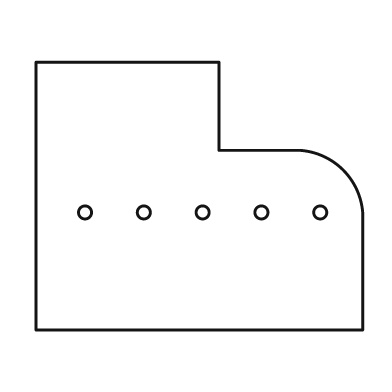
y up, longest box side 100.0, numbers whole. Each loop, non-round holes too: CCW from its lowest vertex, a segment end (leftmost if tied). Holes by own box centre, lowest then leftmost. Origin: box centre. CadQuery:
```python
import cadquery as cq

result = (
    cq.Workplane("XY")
    .moveTo(-50.0, -41.0)
    .lineTo(50.0, -41.0)
    .lineTo(50.0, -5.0)
    .threePointArc((44.0, 8.0), (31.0, 14.0))
    .lineTo(6.0, 14.0)
    .lineTo(6.0, 41.0)
    .lineTo(-50.0, 41.0)
    .close()
    .moveTo(-35.0, -5.0)
    .circle(2.0)
    .moveTo(-17.0, -5.0)
    .circle(2.0)
    .moveTo(1.0, -5.0)
    .circle(2.0)
    .moveTo(19.0, -5.0)
    .circle(2.0)
    .moveTo(37.0, -5.0)
    .circle(2.0)
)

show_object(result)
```